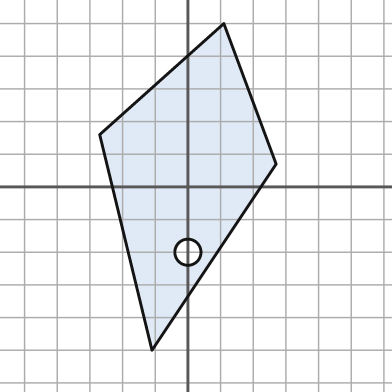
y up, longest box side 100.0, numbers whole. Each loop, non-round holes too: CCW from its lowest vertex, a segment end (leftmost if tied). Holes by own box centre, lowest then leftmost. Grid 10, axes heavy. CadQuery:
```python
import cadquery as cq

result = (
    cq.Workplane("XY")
    .moveTo(-11.0, -50.0)
    .lineTo(27.0, 7.0)
    .lineTo(11.0, 50.0)
    .lineTo(-27.0, 16.0)
    .close()
    .moveTo(0.0, -20.0)
    .circle(4.0)
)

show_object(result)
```